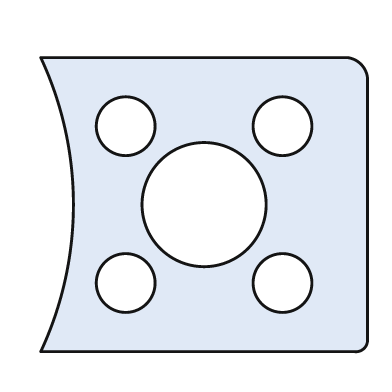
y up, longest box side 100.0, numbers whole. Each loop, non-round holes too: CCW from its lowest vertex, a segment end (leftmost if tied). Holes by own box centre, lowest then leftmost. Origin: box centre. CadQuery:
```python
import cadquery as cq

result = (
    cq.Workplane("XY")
    .moveTo(-50.0, -45.0)
    .lineTo(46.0, -45.0)
    .threePointArc((49.0, -44.0), (50.0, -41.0))
    .lineTo(50.0, 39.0)
    .threePointArc((48.0, 43.0), (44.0, 45.0))
    .lineTo(-50.0, 45.0)
    .threePointArc((-40.0, 0.0), (-50.0, -45.0))
    .close()
    .moveTo(-24.0, -24.0)
    .circle(9.0)
    .moveTo(24.0, -24.0)
    .circle(9.0)
    .moveTo(0.0, 0.0)
    .circle(19.0)
    .moveTo(-24.0, 24.0)
    .circle(9.0)
    .moveTo(24.0, 24.0)
    .circle(9.0)
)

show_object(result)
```